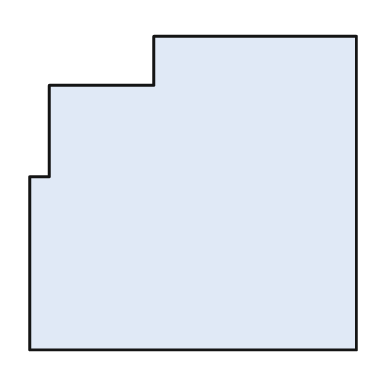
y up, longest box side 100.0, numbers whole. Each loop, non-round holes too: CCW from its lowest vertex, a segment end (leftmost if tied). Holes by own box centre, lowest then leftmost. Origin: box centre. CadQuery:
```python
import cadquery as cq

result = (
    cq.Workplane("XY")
    .moveTo(-50.0, -48.0)
    .lineTo(50.0, -48.0)
    .lineTo(50.0, 48.0)
    .lineTo(-12.0, 48.0)
    .lineTo(-12.0, 33.0)
    .lineTo(-44.0, 33.0)
    .lineTo(-44.0, 5.0)
    .lineTo(-50.0, 5.0)
    .close()
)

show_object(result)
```